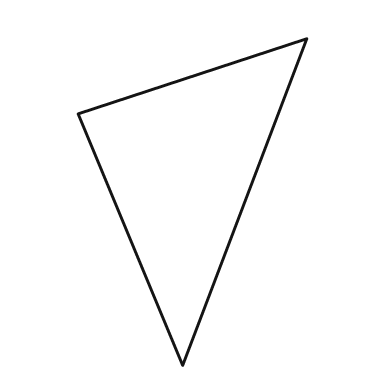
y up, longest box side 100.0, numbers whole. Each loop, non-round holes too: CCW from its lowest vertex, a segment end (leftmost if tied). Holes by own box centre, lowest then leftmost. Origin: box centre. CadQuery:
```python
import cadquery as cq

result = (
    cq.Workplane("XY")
    .moveTo(-3.0, -50.0)
    .lineTo(35.0, 50.0)
    .lineTo(-35.0, 27.0)
    .close()
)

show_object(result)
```